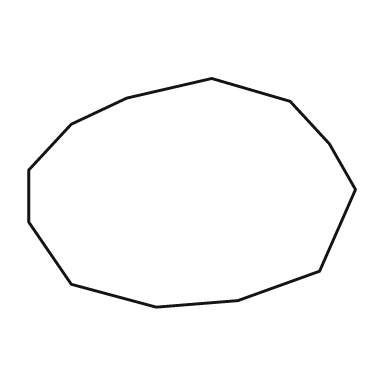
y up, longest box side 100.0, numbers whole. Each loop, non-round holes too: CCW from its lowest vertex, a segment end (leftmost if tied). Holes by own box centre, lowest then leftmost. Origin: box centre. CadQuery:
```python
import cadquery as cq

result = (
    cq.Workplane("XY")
    .moveTo(-11.0, -35.0)
    .lineTo(14.0, -33.0)
    .lineTo(39.0, -24.0)
    .lineTo(50.0, 1.0)
    .lineTo(42.0, 15.0)
    .lineTo(30.0, 28.0)
    .lineTo(6.0, 35.0)
    .lineTo(-20.0, 29.0)
    .lineTo(-37.0, 21.0)
    .lineTo(-50.0, 7.0)
    .lineTo(-50.0, -9.0)
    .lineTo(-37.0, -28.0)
    .close()
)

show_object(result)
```